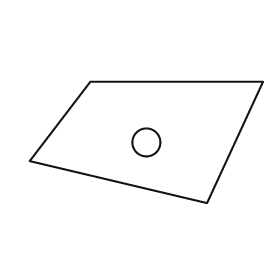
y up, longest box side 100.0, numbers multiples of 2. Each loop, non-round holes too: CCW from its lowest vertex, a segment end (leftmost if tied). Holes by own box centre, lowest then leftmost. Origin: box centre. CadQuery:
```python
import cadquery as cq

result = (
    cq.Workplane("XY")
    .moveTo(26.0, -26.0)
    .lineTo(50.0, 26.0)
    .lineTo(-24.0, 26.0)
    .lineTo(-50.0, -8.0)
    .close()
    .moveTo(0.0, 0.0)
    .circle(6.0)
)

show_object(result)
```